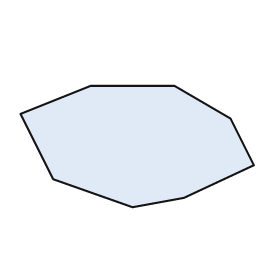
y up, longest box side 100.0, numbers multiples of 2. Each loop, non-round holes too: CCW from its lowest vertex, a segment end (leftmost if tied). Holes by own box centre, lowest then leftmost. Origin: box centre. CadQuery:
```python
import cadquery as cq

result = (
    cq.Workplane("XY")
    .moveTo(-2.0, -26.0)
    .lineTo(20.0, -22.0)
    .lineTo(50.0, -8.0)
    .lineTo(40.0, 12.0)
    .lineTo(16.0, 26.0)
    .lineTo(-20.0, 26.0)
    .lineTo(-50.0, 14.0)
    .lineTo(-36.0, -14.0)
    .close()
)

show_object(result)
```